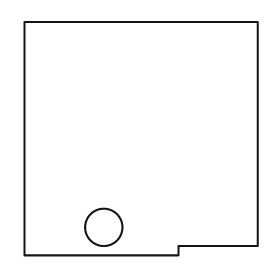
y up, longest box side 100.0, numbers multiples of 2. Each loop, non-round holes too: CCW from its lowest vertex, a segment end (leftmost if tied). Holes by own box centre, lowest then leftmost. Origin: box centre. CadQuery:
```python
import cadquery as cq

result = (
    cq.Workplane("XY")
    .moveTo(-50.0, -50.0)
    .lineTo(16.0, -50.0)
    .lineTo(16.0, -46.0)
    .lineTo(50.0, -46.0)
    .lineTo(50.0, 50.0)
    .lineTo(-50.0, 50.0)
    .close()
    .moveTo(-16.0, -38.0)
    .circle(8.0)
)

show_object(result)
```